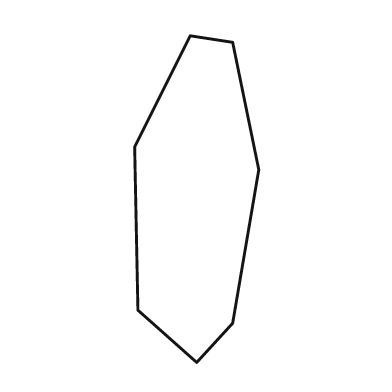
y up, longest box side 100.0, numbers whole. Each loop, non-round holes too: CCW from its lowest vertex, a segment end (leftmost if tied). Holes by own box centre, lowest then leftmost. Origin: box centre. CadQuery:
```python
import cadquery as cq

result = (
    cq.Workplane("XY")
    .moveTo(0.0, -50.0)
    .lineTo(11.0, -38.0)
    .lineTo(19.0, 9.0)
    .lineTo(11.0, 48.0)
    .lineTo(-2.0, 50.0)
    .lineTo(-19.0, 16.0)
    .lineTo(-18.0, -34.0)
    .close()
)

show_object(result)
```